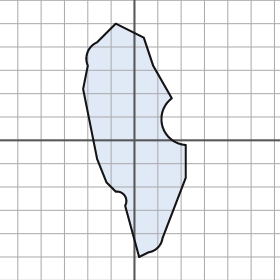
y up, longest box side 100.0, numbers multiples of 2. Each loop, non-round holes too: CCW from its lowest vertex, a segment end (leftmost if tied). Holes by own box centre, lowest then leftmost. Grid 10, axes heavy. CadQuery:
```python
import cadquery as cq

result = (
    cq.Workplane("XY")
    .moveTo(2.0, -50.0)
    .lineTo(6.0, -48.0)
    .threePointArc((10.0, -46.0), (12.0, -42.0))
    .lineTo(22.0, -16.0)
    .lineTo(22.0, -2.0)
    .threePointArc((12.0, 6.0), (16.0, 18.0))
    .lineTo(8.0, 32.0)
    .lineTo(4.0, 44.0)
    .lineTo(-8.0, 50.0)
    .lineTo(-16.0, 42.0)
    .threePointArc((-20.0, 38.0), (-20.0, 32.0))
    .lineTo(-22.0, 22.0)
    .lineTo(-16.0, -8.0)
    .lineTo(-12.0, -18.0)
    .lineTo(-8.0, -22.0)
    .threePointArc((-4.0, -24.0), (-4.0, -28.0))
    .close()
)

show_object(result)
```